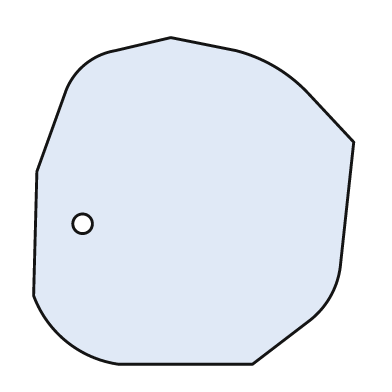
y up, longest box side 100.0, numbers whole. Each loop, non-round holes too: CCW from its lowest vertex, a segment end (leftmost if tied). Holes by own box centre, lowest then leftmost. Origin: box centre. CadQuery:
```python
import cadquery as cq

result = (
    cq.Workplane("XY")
    .moveTo(-23.0, -50.0)
    .lineTo(18.0, -50.0)
    .lineTo(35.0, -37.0)
    .threePointArc((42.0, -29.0), (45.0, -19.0))
    .lineTo(49.0, 18.0)
    .lineTo(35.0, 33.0)
    .threePointArc((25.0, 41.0), (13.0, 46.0))
    .lineTo(-7.0, 50.0)
    .lineTo(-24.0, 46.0)
    .threePointArc((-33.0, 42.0), (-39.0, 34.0))
    .lineTo(-48.0, 9.0)
    .lineTo(-49.0, -29.0)
    .threePointArc((-39.0, -43.0), (-23.0, -50.0))
    .close()
    .moveTo(-34.0, -7.0)
    .circle(3.0)
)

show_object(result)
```